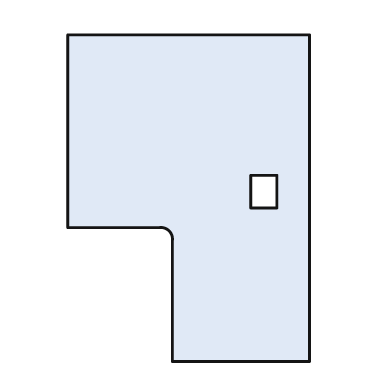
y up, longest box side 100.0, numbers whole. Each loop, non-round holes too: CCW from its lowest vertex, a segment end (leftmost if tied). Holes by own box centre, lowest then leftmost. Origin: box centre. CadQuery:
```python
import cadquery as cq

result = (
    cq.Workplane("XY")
    .moveTo(-5.0, -50.0)
    .lineTo(37.0, -50.0)
    .lineTo(37.0, 50.0)
    .lineTo(-37.0, 50.0)
    .lineTo(-37.0, -9.0)
    .lineTo(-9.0, -9.0)
    .threePointArc((-6.0, -10.0), (-5.0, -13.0))
    .close()
    .moveTo(19.0, -3.0)
    .lineTo(27.0, -3.0)
    .lineTo(27.0, 7.0)
    .lineTo(19.0, 7.0)
    .close()
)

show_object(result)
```